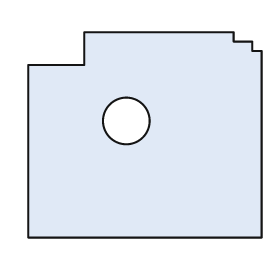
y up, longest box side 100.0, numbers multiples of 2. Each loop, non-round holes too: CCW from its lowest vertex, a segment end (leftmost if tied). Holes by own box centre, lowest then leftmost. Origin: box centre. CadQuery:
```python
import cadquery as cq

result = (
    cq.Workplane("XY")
    .moveTo(-50.0, -44.0)
    .lineTo(50.0, -44.0)
    .lineTo(50.0, 36.0)
    .lineTo(46.0, 36.0)
    .lineTo(46.0, 40.0)
    .lineTo(38.0, 40.0)
    .lineTo(38.0, 44.0)
    .lineTo(-26.0, 44.0)
    .lineTo(-26.0, 30.0)
    .lineTo(-50.0, 30.0)
    .close()
    .moveTo(-8.0, 6.0)
    .circle(10.0)
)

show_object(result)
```